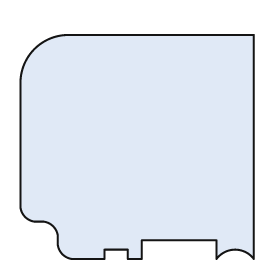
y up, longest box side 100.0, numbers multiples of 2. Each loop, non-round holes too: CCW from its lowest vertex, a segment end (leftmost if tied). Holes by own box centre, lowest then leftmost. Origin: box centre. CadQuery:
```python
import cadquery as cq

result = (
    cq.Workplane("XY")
    .moveTo(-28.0, -48.0)
    .lineTo(-14.0, -48.0)
    .lineTo(-14.0, -44.0)
    .lineTo(-4.0, -44.0)
    .lineTo(-4.0, -48.0)
    .lineTo(2.0, -48.0)
    .lineTo(2.0, -40.0)
    .lineTo(34.0, -40.0)
    .lineTo(34.0, -48.0)
    .threePointArc((42.0, -44.0), (50.0, -48.0))
    .lineTo(50.0, 48.0)
    .lineTo(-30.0, 48.0)
    .threePointArc((-44.0, 42.0), (-50.0, 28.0))
    .lineTo(-50.0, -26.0)
    .threePointArc((-48.0, -30.0), (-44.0, -32.0))
    .lineTo(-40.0, -32.0)
    .threePointArc((-36.0, -34.0), (-34.0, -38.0))
    .lineTo(-34.0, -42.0)
    .threePointArc((-32.0, -46.0), (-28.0, -48.0))
    .close()
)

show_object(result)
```